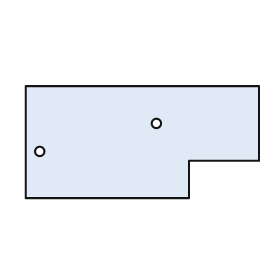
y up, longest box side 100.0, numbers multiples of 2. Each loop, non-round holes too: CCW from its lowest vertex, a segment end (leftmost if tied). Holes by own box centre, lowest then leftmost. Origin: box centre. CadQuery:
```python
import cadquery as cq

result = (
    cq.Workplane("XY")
    .moveTo(-50.0, -24.0)
    .lineTo(20.0, -24.0)
    .lineTo(20.0, -8.0)
    .lineTo(50.0, -8.0)
    .lineTo(50.0, 24.0)
    .lineTo(-50.0, 24.0)
    .close()
    .moveTo(-44.0, -4.0)
    .circle(2.0)
    .moveTo(6.0, 8.0)
    .circle(2.0)
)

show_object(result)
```